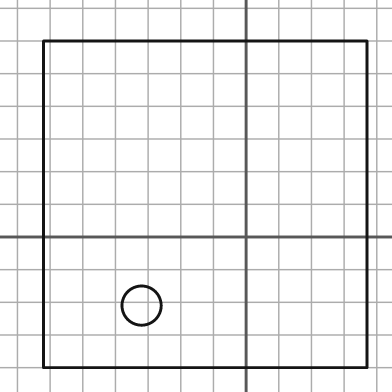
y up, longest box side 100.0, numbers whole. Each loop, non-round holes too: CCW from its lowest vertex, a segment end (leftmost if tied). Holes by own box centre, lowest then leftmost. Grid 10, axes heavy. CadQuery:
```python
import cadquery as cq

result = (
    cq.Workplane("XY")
    .moveTo(-62.0, -40.0)
    .lineTo(37.0, -40.0)
    .lineTo(37.0, 60.0)
    .lineTo(-62.0, 60.0)
    .close()
    .moveTo(-32.0, -21.0)
    .circle(6.0)
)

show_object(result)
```